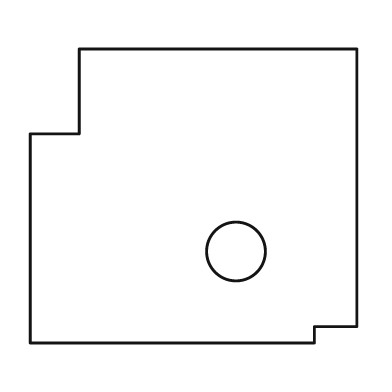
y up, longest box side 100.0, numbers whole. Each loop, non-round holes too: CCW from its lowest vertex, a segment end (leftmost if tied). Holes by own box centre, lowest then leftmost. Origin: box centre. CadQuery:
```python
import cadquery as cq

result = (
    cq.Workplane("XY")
    .moveTo(-50.0, -45.0)
    .lineTo(37.0, -45.0)
    .lineTo(37.0, -40.0)
    .lineTo(50.0, -40.0)
    .lineTo(50.0, 45.0)
    .lineTo(-35.0, 45.0)
    .lineTo(-35.0, 19.0)
    .lineTo(-50.0, 19.0)
    .close()
    .moveTo(13.0, -17.0)
    .circle(9.0)
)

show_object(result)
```